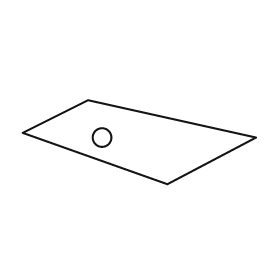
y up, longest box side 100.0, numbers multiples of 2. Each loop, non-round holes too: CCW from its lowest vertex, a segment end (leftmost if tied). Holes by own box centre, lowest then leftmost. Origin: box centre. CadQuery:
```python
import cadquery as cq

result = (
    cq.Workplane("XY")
    .moveTo(12.0, -18.0)
    .lineTo(50.0, 2.0)
    .lineTo(-22.0, 18.0)
    .lineTo(-50.0, 4.0)
    .close()
    .moveTo(-16.0, 2.0)
    .circle(4.0)
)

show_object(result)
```